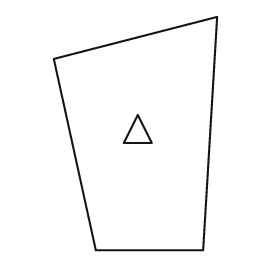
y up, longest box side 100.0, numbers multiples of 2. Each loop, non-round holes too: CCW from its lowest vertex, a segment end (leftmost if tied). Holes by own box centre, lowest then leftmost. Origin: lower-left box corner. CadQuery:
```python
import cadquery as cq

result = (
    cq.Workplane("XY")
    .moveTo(18.0, 0.0)
    .lineTo(64.0, 0.0)
    .lineTo(70.0, 100.0)
    .lineTo(0.0, 82.0)
    .close()
    .moveTo(30.0, 46.0)
    .lineTo(42.0, 46.0)
    .lineTo(36.0, 58.0)
    .close()
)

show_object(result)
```